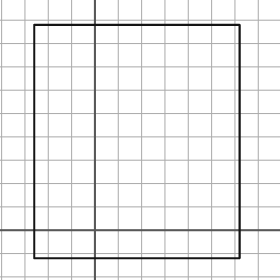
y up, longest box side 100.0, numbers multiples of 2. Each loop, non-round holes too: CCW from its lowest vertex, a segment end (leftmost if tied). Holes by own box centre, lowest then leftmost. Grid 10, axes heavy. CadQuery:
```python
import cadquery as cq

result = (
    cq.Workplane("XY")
    .moveTo(-26.0, -12.0)
    .lineTo(62.0, -12.0)
    .lineTo(62.0, 88.0)
    .lineTo(-26.0, 88.0)
    .close()
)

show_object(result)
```